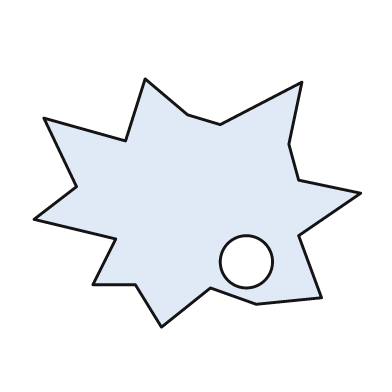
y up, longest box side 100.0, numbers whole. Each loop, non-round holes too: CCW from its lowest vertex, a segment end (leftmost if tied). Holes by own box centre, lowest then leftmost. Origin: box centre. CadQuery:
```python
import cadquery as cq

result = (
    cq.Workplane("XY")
    .moveTo(-11.0, -38.0)
    .lineTo(4.0, -26.0)
    .lineTo(18.0, -31.0)
    .lineTo(38.0, -29.0)
    .lineTo(31.0, -10.0)
    .lineTo(50.0, 3.0)
    .lineTo(31.0, 7.0)
    .lineTo(28.0, 18.0)
    .lineTo(32.0, 37.0)
    .lineTo(7.0, 24.0)
    .lineTo(-3.0, 27.0)
    .lineTo(-16.0, 38.0)
    .lineTo(-22.0, 19.0)
    .lineTo(-47.0, 26.0)
    .lineTo(-37.0, 5.0)
    .lineTo(-50.0, -5.0)
    .lineTo(-25.0, -11.0)
    .lineTo(-32.0, -25.0)
    .lineTo(-19.0, -25.0)
    .close()
    .moveTo(15.0, -18.0)
    .circle(8.0)
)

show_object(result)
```